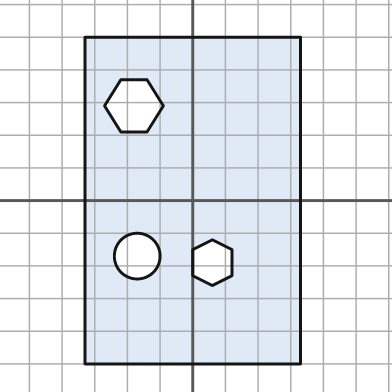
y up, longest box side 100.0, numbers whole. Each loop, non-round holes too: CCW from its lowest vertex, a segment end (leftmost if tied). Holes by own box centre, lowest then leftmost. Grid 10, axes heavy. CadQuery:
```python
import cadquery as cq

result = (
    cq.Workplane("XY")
    .moveTo(-33.0, -50.0)
    .lineTo(33.0, -50.0)
    .lineTo(33.0, 50.0)
    .lineTo(-33.0, 50.0)
    .close()
    .moveTo(6.0, -26.0)
    .lineTo(12.0, -23.0)
    .lineTo(12.0, -15.0)
    .lineTo(6.0, -12.0)
    .lineTo(0.0, -15.0)
    .lineTo(0.0, -23.0)
    .close()
    .moveTo(-17.0, -17.0)
    .circle(7.0)
    .moveTo(-22.0, 21.0)
    .lineTo(-14.0, 21.0)
    .lineTo(-9.0, 29.0)
    .lineTo(-14.0, 37.0)
    .lineTo(-22.0, 37.0)
    .lineTo(-27.0, 29.0)
    .close()
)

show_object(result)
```